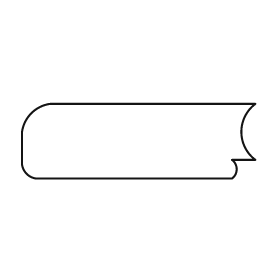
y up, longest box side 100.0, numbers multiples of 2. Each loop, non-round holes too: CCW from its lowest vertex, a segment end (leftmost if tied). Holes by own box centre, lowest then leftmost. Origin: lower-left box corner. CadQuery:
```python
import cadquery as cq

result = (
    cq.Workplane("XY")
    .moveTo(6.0, 0.0)
    .lineTo(90.0, 0.0)
    .threePointArc((92.0, 4.0), (90.0, 8.0))
    .lineTo(100.0, 8.0)
    .threePointArc((94.0, 20.0), (100.0, 32.0))
    .lineTo(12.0, 32.0)
    .threePointArc((4.0, 28.0), (0.0, 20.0))
    .lineTo(0.0, 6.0)
    .threePointArc((2.0, 2.0), (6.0, 0.0))
    .close()
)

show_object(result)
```